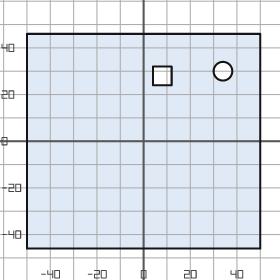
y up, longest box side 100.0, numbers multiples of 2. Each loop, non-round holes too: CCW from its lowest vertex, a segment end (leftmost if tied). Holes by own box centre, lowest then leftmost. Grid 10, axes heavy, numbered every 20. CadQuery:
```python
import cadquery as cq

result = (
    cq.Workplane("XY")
    .moveTo(-50.0, -46.0)
    .lineTo(50.0, -46.0)
    .lineTo(50.0, 46.0)
    .lineTo(-50.0, 46.0)
    .close()
    .moveTo(4.0, 24.0)
    .lineTo(12.0, 24.0)
    .lineTo(12.0, 32.0)
    .lineTo(4.0, 32.0)
    .close()
    .moveTo(34.0, 30.0)
    .circle(4.0)
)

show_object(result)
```